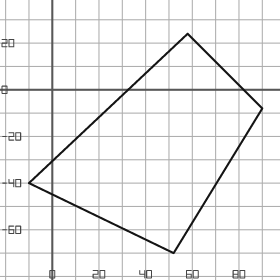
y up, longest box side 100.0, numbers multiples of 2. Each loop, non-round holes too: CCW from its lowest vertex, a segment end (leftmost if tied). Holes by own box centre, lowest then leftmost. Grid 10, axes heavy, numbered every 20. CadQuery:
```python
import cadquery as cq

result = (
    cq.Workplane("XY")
    .moveTo(52.0, -70.0)
    .lineTo(90.0, -8.0)
    .lineTo(58.0, 24.0)
    .lineTo(-10.0, -40.0)
    .close()
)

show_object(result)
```